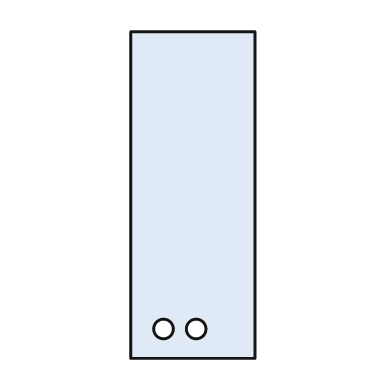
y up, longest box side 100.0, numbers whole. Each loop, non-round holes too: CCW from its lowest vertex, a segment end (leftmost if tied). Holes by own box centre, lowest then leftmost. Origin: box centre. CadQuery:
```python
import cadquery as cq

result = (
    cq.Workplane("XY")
    .moveTo(-19.0, -50.0)
    .lineTo(19.0, -50.0)
    .lineTo(19.0, 50.0)
    .lineTo(-19.0, 50.0)
    .close()
    .moveTo(-9.0, -41.0)
    .circle(3.0)
    .moveTo(1.0, -41.0)
    .circle(3.0)
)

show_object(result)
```